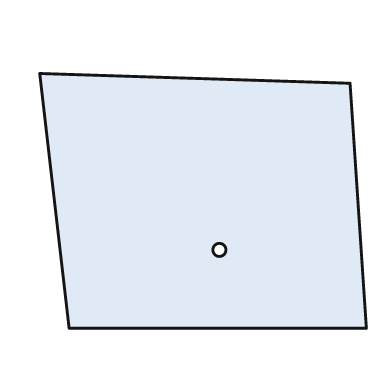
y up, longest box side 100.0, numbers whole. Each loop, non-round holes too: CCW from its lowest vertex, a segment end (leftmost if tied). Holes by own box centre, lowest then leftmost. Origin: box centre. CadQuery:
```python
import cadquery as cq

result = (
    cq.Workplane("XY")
    .moveTo(-41.0, -39.0)
    .lineTo(50.0, -39.0)
    .lineTo(45.0, 36.0)
    .lineTo(-50.0, 39.0)
    .close()
    .moveTo(5.0, -15.0)
    .circle(2.0)
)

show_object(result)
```